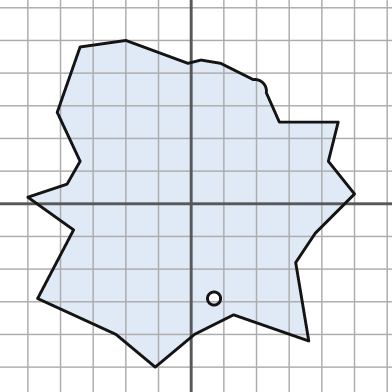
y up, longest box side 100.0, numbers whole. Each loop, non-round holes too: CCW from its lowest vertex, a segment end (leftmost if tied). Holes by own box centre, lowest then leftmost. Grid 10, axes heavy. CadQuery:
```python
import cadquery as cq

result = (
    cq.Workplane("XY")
    .moveTo(-11.0, -50.0)
    .lineTo(1.0, -40.0)
    .lineTo(13.0, -34.0)
    .lineTo(36.0, -42.0)
    .lineTo(32.0, -18.0)
    .lineTo(38.0, -9.0)
    .lineTo(50.0, 3.0)
    .lineTo(42.0, 13.0)
    .lineTo(45.0, 25.0)
    .lineTo(27.0, 25.0)
    .lineTo(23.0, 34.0)
    .threePointArc((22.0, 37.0), (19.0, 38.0))
    .lineTo(9.0, 43.0)
    .lineTo(3.0, 44.0)
    .lineTo(-1.0, 43.0)
    .lineTo(-20.0, 50.0)
    .lineTo(-34.0, 48.0)
    .lineTo(-41.0, 28.0)
    .lineTo(-34.0, 13.0)
    .lineTo(-38.0, 6.0)
    .lineTo(-50.0, 2.0)
    .lineTo(-36.0, -8.0)
    .lineTo(-47.0, -29.0)
    .lineTo(-23.0, -40.0)
    .close()
    .moveTo(7.0, -29.0)
    .circle(2.0)
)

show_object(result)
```